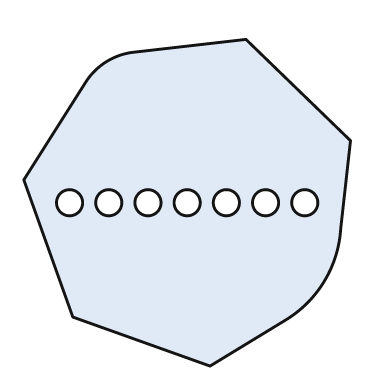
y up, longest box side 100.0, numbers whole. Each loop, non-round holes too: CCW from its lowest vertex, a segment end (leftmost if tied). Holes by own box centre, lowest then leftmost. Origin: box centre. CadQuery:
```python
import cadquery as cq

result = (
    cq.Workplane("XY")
    .moveTo(7.0, -50.0)
    .lineTo(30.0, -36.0)
    .threePointArc((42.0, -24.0), (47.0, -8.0))
    .lineTo(50.0, 19.0)
    .lineTo(18.0, 50.0)
    .lineTo(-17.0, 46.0)
    .threePointArc((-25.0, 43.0), (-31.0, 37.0))
    .lineTo(-50.0, 7.0)
    .lineTo(-35.0, -35.0)
    .close()
    .moveTo(-36.0, 0.0)
    .circle(4.0)
    .moveTo(-24.0, 0.0)
    .circle(4.0)
    .moveTo(-12.0, 0.0)
    .circle(4.0)
    .moveTo(0.0, 0.0)
    .circle(4.0)
    .moveTo(12.0, 0.0)
    .circle(4.0)
    .moveTo(24.0, 0.0)
    .circle(4.0)
    .moveTo(36.0, 0.0)
    .circle(4.0)
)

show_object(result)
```